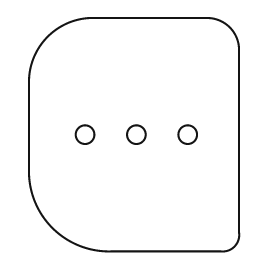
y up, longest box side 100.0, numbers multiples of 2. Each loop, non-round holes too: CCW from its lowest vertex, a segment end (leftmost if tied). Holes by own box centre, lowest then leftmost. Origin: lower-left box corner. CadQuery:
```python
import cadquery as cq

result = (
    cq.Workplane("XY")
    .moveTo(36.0, 0.0)
    .lineTo(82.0, 0.0)
    .threePointArc((88.0, 2.0), (90.0, 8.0))
    .lineTo(90.0, 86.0)
    .threePointArc((86.0, 96.0), (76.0, 100.0))
    .lineTo(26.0, 100.0)
    .threePointArc((8.0, 92.0), (0.0, 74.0))
    .lineTo(0.0, 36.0)
    .threePointArc((10.0, 10.0), (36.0, 0.0))
    .close()
    .moveTo(24.0, 50.0)
    .circle(4.0)
    .moveTo(46.0, 50.0)
    .circle(4.0)
    .moveTo(68.0, 50.0)
    .circle(4.0)
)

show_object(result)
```